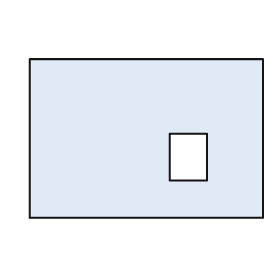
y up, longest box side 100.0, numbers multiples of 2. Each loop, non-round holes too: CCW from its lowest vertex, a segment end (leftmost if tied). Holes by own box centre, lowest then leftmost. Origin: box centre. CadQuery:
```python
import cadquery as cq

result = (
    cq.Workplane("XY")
    .moveTo(-50.0, -34.0)
    .lineTo(50.0, -34.0)
    .lineTo(50.0, 34.0)
    .lineTo(-50.0, 34.0)
    .close()
    .moveTo(10.0, -18.0)
    .lineTo(26.0, -18.0)
    .lineTo(26.0, 2.0)
    .lineTo(10.0, 2.0)
    .close()
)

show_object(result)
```